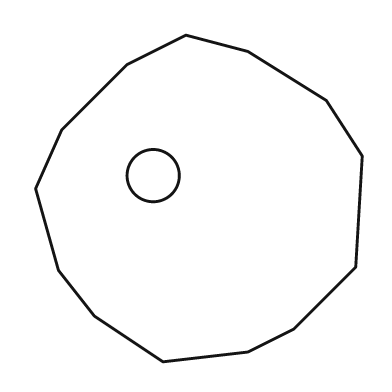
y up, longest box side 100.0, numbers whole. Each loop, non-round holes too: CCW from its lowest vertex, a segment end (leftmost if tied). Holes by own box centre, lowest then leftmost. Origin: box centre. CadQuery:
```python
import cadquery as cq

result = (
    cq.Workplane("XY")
    .moveTo(-11.0, -50.0)
    .lineTo(15.0, -47.0)
    .lineTo(29.0, -40.0)
    .lineTo(48.0, -21.0)
    .lineTo(50.0, 13.0)
    .lineTo(39.0, 30.0)
    .lineTo(15.0, 45.0)
    .lineTo(-4.0, 50.0)
    .lineTo(-22.0, 41.0)
    .lineTo(-42.0, 21.0)
    .lineTo(-50.0, 3.0)
    .lineTo(-43.0, -22.0)
    .lineTo(-32.0, -36.0)
    .close()
    .moveTo(-14.0, 7.0)
    .circle(8.0)
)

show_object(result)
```